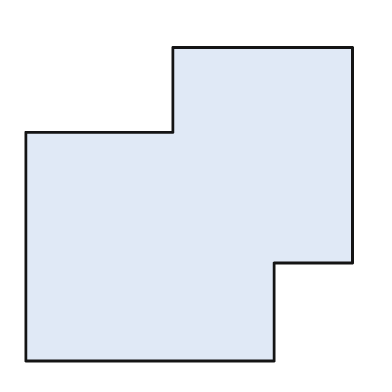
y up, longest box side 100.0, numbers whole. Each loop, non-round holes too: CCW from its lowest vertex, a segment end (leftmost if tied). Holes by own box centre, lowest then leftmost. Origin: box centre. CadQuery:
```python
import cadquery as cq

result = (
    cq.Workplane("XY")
    .moveTo(-50.0, -48.0)
    .lineTo(26.0, -48.0)
    .lineTo(26.0, -18.0)
    .lineTo(50.0, -18.0)
    .lineTo(50.0, 48.0)
    .lineTo(-5.0, 48.0)
    .lineTo(-5.0, 22.0)
    .lineTo(-50.0, 22.0)
    .close()
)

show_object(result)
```